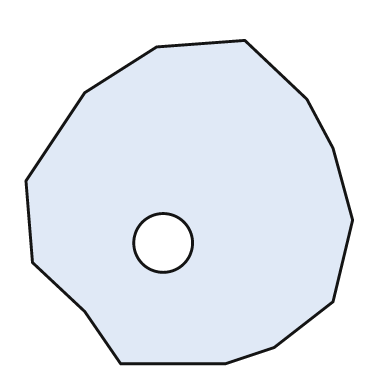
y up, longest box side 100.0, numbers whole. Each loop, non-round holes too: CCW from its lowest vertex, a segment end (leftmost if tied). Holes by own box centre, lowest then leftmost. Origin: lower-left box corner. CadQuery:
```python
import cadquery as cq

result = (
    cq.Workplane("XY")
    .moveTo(29.0, 0.0)
    .lineTo(61.0, 0.0)
    .lineTo(76.0, 5.0)
    .lineTo(94.0, 19.0)
    .lineTo(100.0, 44.0)
    .lineTo(94.0, 66.0)
    .lineTo(86.0, 81.0)
    .lineTo(67.0, 99.0)
    .lineTo(40.0, 97.0)
    .lineTo(18.0, 83.0)
    .lineTo(0.0, 56.0)
    .lineTo(2.0, 31.0)
    .lineTo(18.0, 16.0)
    .close()
    .moveTo(42.0, 37.0)
    .circle(9.0)
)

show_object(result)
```